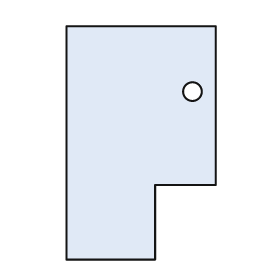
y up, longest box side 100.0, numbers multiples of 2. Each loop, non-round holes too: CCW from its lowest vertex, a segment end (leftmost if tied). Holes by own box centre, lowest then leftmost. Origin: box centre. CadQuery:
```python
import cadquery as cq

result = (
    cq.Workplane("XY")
    .moveTo(-32.0, -50.0)
    .lineTo(6.0, -50.0)
    .lineTo(6.0, -18.0)
    .lineTo(32.0, -18.0)
    .lineTo(32.0, 50.0)
    .lineTo(-32.0, 50.0)
    .close()
    .moveTo(22.0, 22.0)
    .circle(4.0)
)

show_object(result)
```